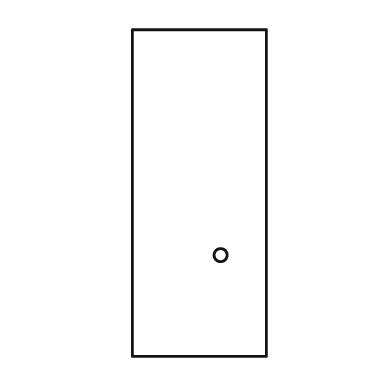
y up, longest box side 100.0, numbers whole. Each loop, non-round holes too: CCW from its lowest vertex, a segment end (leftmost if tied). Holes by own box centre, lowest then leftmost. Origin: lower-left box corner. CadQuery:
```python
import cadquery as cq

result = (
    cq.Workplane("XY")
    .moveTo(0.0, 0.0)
    .lineTo(41.0, 0.0)
    .lineTo(41.0, 100.0)
    .lineTo(0.0, 100.0)
    .close()
    .moveTo(27.0, 31.0)
    .circle(2.0)
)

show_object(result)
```